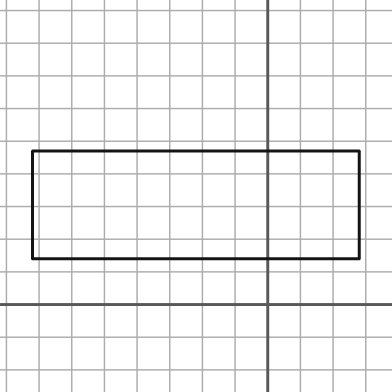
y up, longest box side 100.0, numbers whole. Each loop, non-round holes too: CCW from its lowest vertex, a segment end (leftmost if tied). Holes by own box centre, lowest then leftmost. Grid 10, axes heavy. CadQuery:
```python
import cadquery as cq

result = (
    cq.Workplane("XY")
    .moveTo(-72.0, 14.0)
    .lineTo(28.0, 14.0)
    .lineTo(28.0, 47.0)
    .lineTo(-72.0, 47.0)
    .close()
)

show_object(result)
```